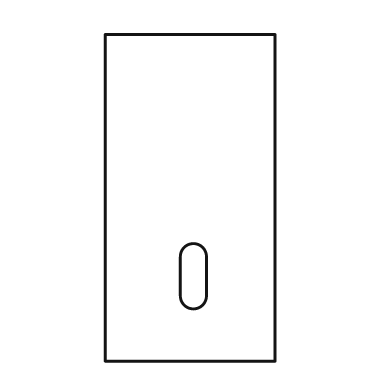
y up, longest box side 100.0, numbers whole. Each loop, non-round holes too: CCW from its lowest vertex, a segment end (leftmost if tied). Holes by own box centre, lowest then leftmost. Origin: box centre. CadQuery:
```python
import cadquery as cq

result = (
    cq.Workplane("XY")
    .moveTo(-26.0, -50.0)
    .lineTo(26.0, -50.0)
    .lineTo(26.0, 50.0)
    .lineTo(-26.0, 50.0)
    .close()
    .moveTo(-3.0, -30.0)
    .threePointArc((1.0, -34.0), (5.0, -30.0))
    .lineTo(5.0, -18.0)
    .threePointArc((1.0, -14.0), (-3.0, -18.0))
    .close()
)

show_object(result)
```